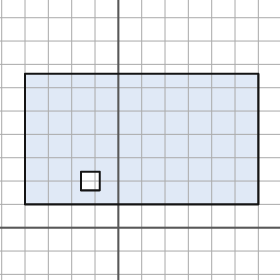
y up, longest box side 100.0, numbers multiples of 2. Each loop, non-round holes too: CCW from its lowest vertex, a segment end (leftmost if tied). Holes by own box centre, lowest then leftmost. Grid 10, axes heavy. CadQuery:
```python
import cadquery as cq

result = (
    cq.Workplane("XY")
    .moveTo(-40.0, 10.0)
    .lineTo(60.0, 10.0)
    .lineTo(60.0, 66.0)
    .lineTo(-40.0, 66.0)
    .close()
    .moveTo(-16.0, 16.0)
    .lineTo(-8.0, 16.0)
    .lineTo(-8.0, 24.0)
    .lineTo(-16.0, 24.0)
    .close()
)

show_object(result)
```